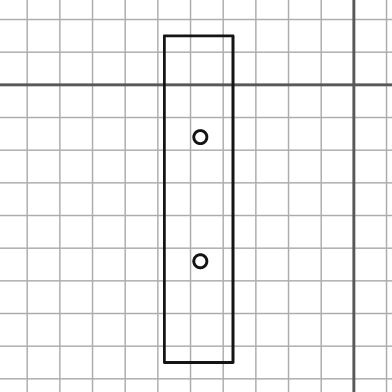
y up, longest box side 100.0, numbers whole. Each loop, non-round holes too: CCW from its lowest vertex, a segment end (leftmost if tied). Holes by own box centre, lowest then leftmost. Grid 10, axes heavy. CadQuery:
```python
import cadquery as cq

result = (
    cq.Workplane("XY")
    .moveTo(-58.0, -85.0)
    .lineTo(-37.0, -85.0)
    .lineTo(-37.0, 15.0)
    .lineTo(-58.0, 15.0)
    .close()
    .moveTo(-47.0, -54.0)
    .circle(2.0)
    .moveTo(-47.0, -16.0)
    .circle(2.0)
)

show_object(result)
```